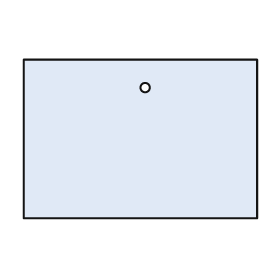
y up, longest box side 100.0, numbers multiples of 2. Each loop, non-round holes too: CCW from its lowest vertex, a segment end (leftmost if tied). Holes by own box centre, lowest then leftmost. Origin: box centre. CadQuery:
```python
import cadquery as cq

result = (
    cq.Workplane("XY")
    .moveTo(-50.0, -34.0)
    .lineTo(50.0, -34.0)
    .lineTo(50.0, 34.0)
    .lineTo(-50.0, 34.0)
    .close()
    .moveTo(2.0, 22.0)
    .circle(2.0)
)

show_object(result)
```